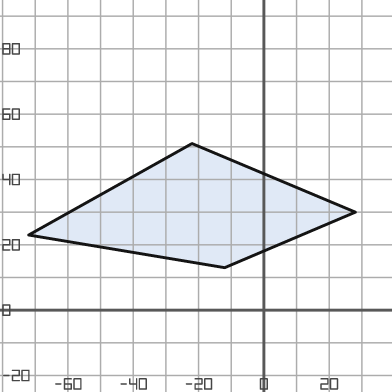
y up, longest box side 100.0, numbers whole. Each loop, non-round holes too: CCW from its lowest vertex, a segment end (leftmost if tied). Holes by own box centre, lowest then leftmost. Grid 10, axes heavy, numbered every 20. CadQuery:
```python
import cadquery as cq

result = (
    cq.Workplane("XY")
    .moveTo(-12.0, 13.0)
    .lineTo(28.0, 30.0)
    .lineTo(-22.0, 51.0)
    .lineTo(-72.0, 23.0)
    .close()
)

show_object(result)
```